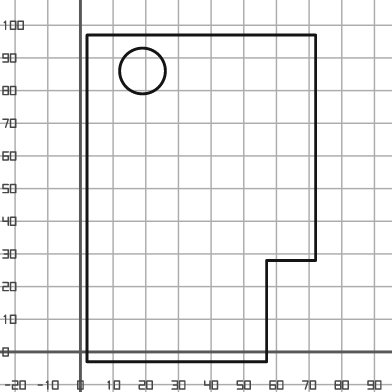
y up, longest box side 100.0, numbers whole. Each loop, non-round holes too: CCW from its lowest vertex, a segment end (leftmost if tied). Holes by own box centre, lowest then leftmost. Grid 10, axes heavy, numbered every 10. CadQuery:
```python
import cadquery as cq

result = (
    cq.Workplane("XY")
    .moveTo(2.0, -3.0)
    .lineTo(57.0, -3.0)
    .lineTo(57.0, 28.0)
    .lineTo(72.0, 28.0)
    .lineTo(72.0, 97.0)
    .lineTo(2.0, 97.0)
    .close()
    .moveTo(19.0, 86.0)
    .circle(7.0)
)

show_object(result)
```